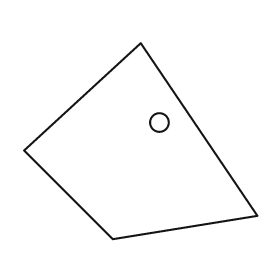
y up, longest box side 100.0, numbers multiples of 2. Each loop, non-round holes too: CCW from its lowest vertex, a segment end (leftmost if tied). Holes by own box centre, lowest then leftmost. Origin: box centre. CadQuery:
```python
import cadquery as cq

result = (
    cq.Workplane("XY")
    .moveTo(-12.0, -42.0)
    .lineTo(50.0, -32.0)
    .lineTo(0.0, 42.0)
    .lineTo(-50.0, -4.0)
    .close()
    .moveTo(8.0, 8.0)
    .circle(4.0)
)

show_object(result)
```